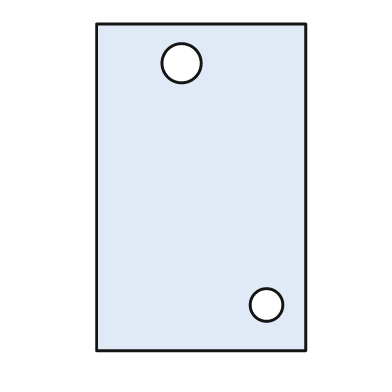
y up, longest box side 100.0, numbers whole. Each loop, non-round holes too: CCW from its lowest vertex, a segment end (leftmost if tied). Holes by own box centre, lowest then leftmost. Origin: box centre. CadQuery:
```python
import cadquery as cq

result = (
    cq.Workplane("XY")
    .moveTo(-32.0, -50.0)
    .lineTo(32.0, -50.0)
    .lineTo(32.0, 50.0)
    .lineTo(-32.0, 50.0)
    .close()
    .moveTo(20.0, -36.0)
    .circle(5.0)
    .moveTo(-6.0, 38.0)
    .circle(6.0)
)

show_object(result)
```